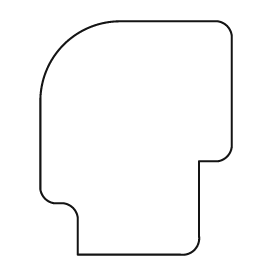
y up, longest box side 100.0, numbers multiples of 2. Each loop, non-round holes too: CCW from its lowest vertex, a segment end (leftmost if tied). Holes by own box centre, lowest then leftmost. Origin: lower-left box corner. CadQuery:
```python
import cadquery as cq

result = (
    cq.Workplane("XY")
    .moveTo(16.0, 0.0)
    .lineTo(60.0, 0.0)
    .threePointArc((66.0, 2.0), (68.0, 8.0))
    .lineTo(68.0, 40.0)
    .lineTo(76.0, 40.0)
    .threePointArc((80.0, 42.0), (82.0, 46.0))
    .lineTo(82.0, 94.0)
    .threePointArc((80.0, 98.0), (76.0, 100.0))
    .lineTo(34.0, 100.0)
    .threePointArc((10.0, 90.0), (0.0, 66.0))
    .lineTo(0.0, 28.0)
    .threePointArc((2.0, 24.0), (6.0, 22.0))
    .lineTo(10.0, 22.0)
    .threePointArc((14.0, 20.0), (16.0, 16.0))
    .close()
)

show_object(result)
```